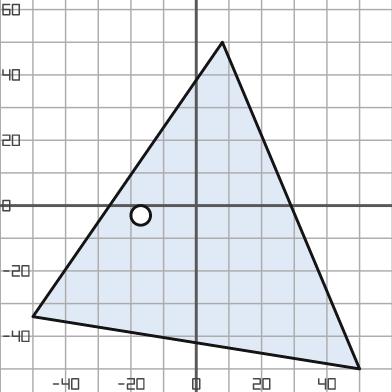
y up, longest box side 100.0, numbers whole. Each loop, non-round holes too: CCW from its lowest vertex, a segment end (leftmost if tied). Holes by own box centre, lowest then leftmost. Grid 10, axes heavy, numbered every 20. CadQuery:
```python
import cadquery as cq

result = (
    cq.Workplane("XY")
    .moveTo(50.0, -50.0)
    .lineTo(8.0, 50.0)
    .lineTo(-50.0, -34.0)
    .close()
    .moveTo(-17.0, -3.0)
    .circle(3.0)
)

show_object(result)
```